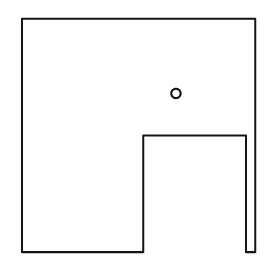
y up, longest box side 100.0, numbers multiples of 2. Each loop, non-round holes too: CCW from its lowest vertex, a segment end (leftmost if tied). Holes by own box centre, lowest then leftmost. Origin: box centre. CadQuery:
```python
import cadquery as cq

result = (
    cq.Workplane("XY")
    .moveTo(-50.0, -50.0)
    .lineTo(2.0, -50.0)
    .lineTo(2.0, 0.0)
    .lineTo(46.0, 0.0)
    .lineTo(46.0, -50.0)
    .lineTo(50.0, -50.0)
    .lineTo(50.0, 50.0)
    .lineTo(-50.0, 50.0)
    .close()
    .moveTo(16.0, 18.0)
    .circle(2.0)
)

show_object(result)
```